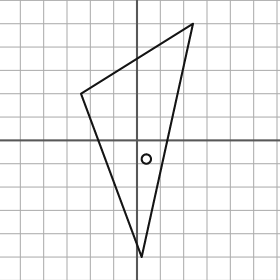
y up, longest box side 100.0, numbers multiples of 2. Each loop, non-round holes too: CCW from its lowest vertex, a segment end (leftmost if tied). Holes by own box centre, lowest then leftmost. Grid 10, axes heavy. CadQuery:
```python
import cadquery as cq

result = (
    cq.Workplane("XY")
    .moveTo(2.0, -50.0)
    .lineTo(24.0, 50.0)
    .lineTo(-24.0, 20.0)
    .close()
    .moveTo(4.0, -8.0)
    .circle(2.0)
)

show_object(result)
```